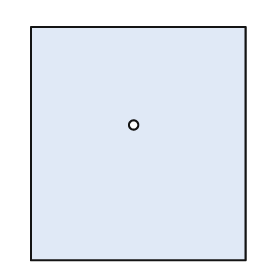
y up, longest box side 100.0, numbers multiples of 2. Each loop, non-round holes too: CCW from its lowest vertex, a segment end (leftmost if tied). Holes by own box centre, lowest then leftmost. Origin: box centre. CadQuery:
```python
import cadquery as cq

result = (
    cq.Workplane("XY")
    .moveTo(-46.0, -50.0)
    .lineTo(46.0, -50.0)
    .lineTo(46.0, 50.0)
    .lineTo(-46.0, 50.0)
    .close()
    .moveTo(-2.0, 8.0)
    .circle(2.0)
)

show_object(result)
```